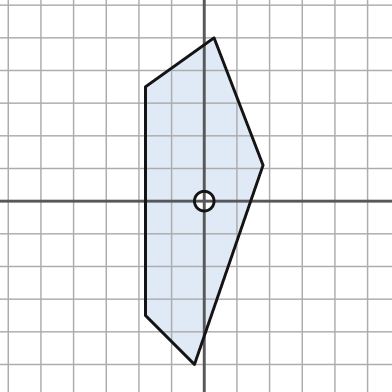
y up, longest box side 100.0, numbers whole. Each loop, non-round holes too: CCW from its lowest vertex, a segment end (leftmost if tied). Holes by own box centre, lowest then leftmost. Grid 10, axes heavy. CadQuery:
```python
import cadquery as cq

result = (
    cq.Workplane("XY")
    .moveTo(-3.0, -50.0)
    .lineTo(18.0, 11.0)
    .lineTo(3.0, 50.0)
    .lineTo(-18.0, 35.0)
    .lineTo(-18.0, -35.0)
    .close()
    .moveTo(0.0, 0.0)
    .circle(3.0)
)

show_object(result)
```